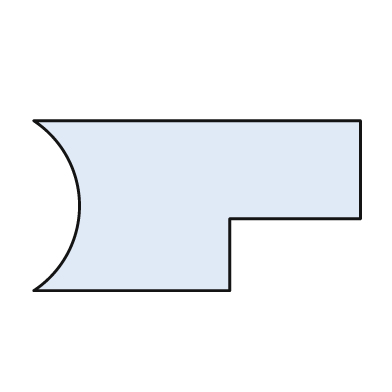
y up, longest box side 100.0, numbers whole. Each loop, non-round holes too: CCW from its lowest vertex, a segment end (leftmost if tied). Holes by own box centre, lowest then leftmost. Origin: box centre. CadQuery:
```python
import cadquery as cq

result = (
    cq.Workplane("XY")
    .moveTo(-50.0, -26.0)
    .lineTo(10.0, -26.0)
    .lineTo(10.0, -4.0)
    .lineTo(50.0, -4.0)
    .lineTo(50.0, 26.0)
    .lineTo(-50.0, 26.0)
    .threePointArc((-36.0, 0.0), (-50.0, -26.0))
    .close()
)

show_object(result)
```